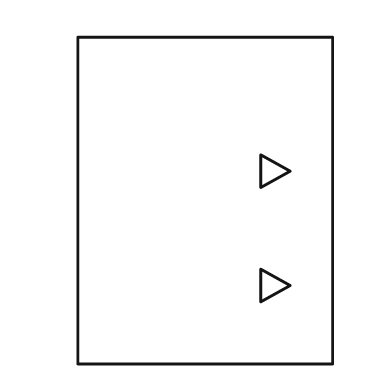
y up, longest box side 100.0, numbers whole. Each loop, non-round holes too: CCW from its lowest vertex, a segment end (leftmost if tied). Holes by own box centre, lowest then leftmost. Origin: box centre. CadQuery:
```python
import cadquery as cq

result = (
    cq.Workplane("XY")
    .moveTo(-39.0, -50.0)
    .lineTo(39.0, -50.0)
    .lineTo(39.0, 50.0)
    .lineTo(-39.0, 50.0)
    .close()
    .moveTo(17.0, -31.0)
    .lineTo(26.0, -26.0)
    .lineTo(17.0, -21.0)
    .close()
    .moveTo(17.0, 4.0)
    .lineTo(26.0, 9.0)
    .lineTo(17.0, 14.0)
    .close()
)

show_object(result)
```